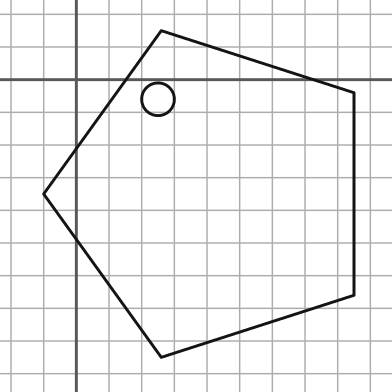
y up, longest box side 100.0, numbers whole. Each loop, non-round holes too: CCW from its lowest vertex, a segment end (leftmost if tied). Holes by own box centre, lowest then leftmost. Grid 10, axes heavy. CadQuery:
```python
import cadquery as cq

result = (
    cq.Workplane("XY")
    .moveTo(26.0, -85.0)
    .lineTo(85.0, -66.0)
    .lineTo(85.0, -4.0)
    .lineTo(26.0, 15.0)
    .lineTo(-10.0, -35.0)
    .close()
    .moveTo(25.0, -6.0)
    .circle(5.0)
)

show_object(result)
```